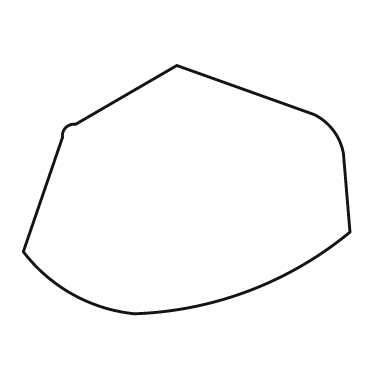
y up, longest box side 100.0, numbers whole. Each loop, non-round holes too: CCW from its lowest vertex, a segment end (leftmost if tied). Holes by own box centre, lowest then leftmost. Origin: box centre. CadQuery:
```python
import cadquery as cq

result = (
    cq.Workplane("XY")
    .moveTo(-16.0, -38.0)
    .threePointArc((19.0, -31.0), (50.0, -13.0))
    .lineTo(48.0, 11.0)
    .threePointArc((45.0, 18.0), (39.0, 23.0))
    .lineTo(-3.0, 38.0)
    .lineTo(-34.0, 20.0)
    .threePointArc((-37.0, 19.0), (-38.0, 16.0))
    .lineTo(-50.0, -19.0)
    .threePointArc((-35.0, -32.0), (-16.0, -38.0))
    .close()
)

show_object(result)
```